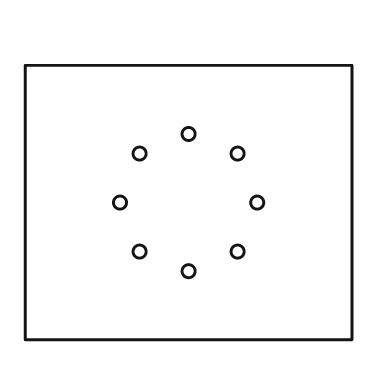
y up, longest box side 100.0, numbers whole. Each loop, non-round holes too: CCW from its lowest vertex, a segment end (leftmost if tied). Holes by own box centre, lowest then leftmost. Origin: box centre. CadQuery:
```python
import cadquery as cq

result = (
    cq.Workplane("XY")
    .moveTo(-50.0, -42.0)
    .lineTo(50.0, -42.0)
    .lineTo(50.0, 42.0)
    .lineTo(-50.0, 42.0)
    .close()
    .moveTo(0.0, -21.0)
    .circle(2.0)
    .moveTo(-15.0, -15.0)
    .circle(2.0)
    .moveTo(15.0, -15.0)
    .circle(2.0)
    .moveTo(-21.0, 0.0)
    .circle(2.0)
    .moveTo(21.0, 0.0)
    .circle(2.0)
    .moveTo(-15.0, 15.0)
    .circle(2.0)
    .moveTo(15.0, 15.0)
    .circle(2.0)
    .moveTo(0.0, 21.0)
    .circle(2.0)
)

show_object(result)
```